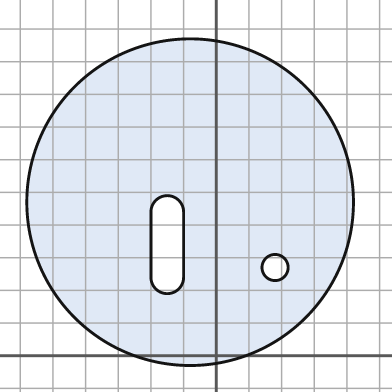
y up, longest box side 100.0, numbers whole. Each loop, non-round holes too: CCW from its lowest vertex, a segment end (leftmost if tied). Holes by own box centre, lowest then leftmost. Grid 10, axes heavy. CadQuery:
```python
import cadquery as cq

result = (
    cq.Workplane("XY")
    .moveTo(-8.0, 47.0)
    .circle(50.0)
    .moveTo(18.0, 27.0)
    .circle(4.0)
    .moveTo(-20.0, 24.0)
    .threePointArc((-15.0, 19.0), (-10.0, 24.0))
    .lineTo(-10.0, 44.0)
    .threePointArc((-15.0, 49.0), (-20.0, 44.0))
    .close()
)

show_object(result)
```